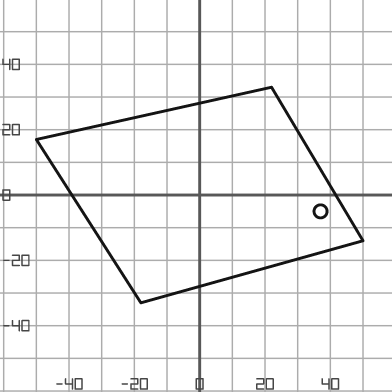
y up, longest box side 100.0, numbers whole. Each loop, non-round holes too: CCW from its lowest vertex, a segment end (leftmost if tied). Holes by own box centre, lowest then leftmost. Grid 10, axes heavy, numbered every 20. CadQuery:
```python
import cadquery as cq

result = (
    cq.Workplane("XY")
    .moveTo(-18.0, -33.0)
    .lineTo(50.0, -14.0)
    .lineTo(22.0, 33.0)
    .lineTo(-50.0, 17.0)
    .close()
    .moveTo(37.0, -5.0)
    .circle(2.0)
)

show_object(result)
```